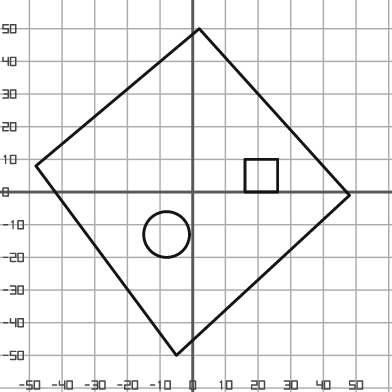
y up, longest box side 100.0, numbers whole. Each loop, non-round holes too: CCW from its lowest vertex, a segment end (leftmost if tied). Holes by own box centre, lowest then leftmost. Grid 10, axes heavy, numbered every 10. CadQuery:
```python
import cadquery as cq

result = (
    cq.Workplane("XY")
    .moveTo(-5.0, -50.0)
    .lineTo(48.0, -1.0)
    .lineTo(2.0, 50.0)
    .lineTo(-48.0, 8.0)
    .close()
    .moveTo(-8.0, -13.0)
    .circle(7.0)
    .moveTo(16.0, 0.0)
    .lineTo(26.0, 0.0)
    .lineTo(26.0, 10.0)
    .lineTo(16.0, 10.0)
    .close()
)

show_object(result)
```